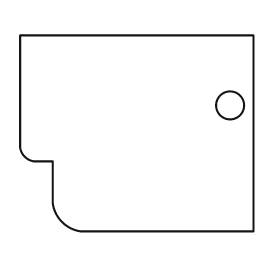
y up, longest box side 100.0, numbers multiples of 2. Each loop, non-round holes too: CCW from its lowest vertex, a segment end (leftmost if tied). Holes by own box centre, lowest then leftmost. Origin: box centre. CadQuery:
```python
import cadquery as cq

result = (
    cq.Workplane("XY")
    .moveTo(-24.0, -42.0)
    .lineTo(50.0, -42.0)
    .lineTo(50.0, 42.0)
    .lineTo(-50.0, 42.0)
    .lineTo(-50.0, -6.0)
    .threePointArc((-48.0, -10.0), (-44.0, -12.0))
    .lineTo(-36.0, -12.0)
    .lineTo(-36.0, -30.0)
    .threePointArc((-32.0, -38.0), (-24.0, -42.0))
    .close()
    .moveTo(40.0, 12.0)
    .circle(6.0)
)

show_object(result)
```